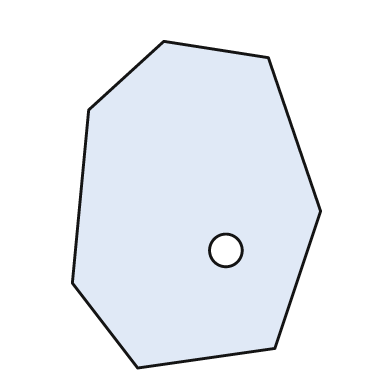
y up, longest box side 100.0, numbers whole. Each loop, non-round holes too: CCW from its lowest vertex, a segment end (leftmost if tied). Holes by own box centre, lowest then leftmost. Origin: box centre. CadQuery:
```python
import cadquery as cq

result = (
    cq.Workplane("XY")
    .moveTo(-18.0, -50.0)
    .lineTo(24.0, -44.0)
    .lineTo(38.0, -2.0)
    .lineTo(22.0, 45.0)
    .lineTo(-10.0, 50.0)
    .lineTo(-33.0, 29.0)
    .lineTo(-38.0, -24.0)
    .close()
    .moveTo(9.0, -14.0)
    .circle(5.0)
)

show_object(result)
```